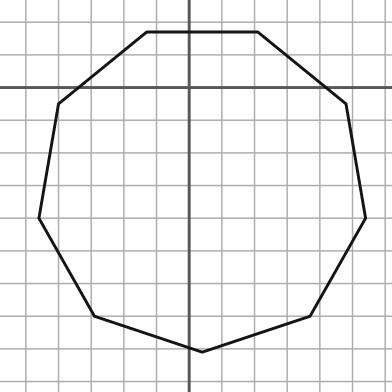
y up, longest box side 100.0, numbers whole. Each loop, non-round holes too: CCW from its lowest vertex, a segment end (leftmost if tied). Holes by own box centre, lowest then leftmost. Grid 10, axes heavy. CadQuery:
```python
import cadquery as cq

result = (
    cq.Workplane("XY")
    .moveTo(4.0, -81.0)
    .lineTo(37.0, -70.0)
    .lineTo(54.0, -40.0)
    .lineTo(48.0, -5.0)
    .lineTo(21.0, 17.0)
    .lineTo(-13.0, 17.0)
    .lineTo(-40.0, -5.0)
    .lineTo(-46.0, -40.0)
    .lineTo(-29.0, -70.0)
    .close()
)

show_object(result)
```